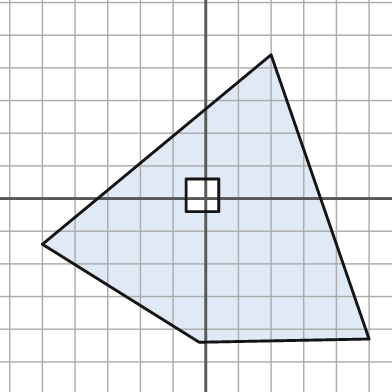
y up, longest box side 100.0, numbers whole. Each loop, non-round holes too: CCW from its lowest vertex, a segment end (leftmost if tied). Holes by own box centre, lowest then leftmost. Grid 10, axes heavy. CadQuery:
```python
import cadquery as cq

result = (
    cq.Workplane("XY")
    .moveTo(-2.0, -44.0)
    .lineTo(50.0, -43.0)
    .lineTo(20.0, 44.0)
    .lineTo(-50.0, -14.0)
    .close()
    .moveTo(-6.0, -4.0)
    .lineTo(4.0, -4.0)
    .lineTo(4.0, 6.0)
    .lineTo(-6.0, 6.0)
    .close()
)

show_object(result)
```